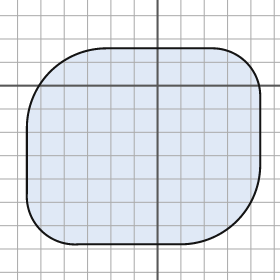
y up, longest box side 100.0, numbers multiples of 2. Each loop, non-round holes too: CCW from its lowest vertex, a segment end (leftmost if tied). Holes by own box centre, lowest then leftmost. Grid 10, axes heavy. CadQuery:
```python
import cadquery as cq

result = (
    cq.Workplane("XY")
    .moveTo(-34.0, -68.0)
    .lineTo(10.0, -68.0)
    .threePointArc((34.0, -58.0), (44.0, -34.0))
    .lineTo(44.0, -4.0)
    .threePointArc((38.0, 10.0), (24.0, 16.0))
    .lineTo(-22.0, 16.0)
    .threePointArc((-46.0, 6.0), (-56.0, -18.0))
    .lineTo(-56.0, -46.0)
    .threePointArc((-50.0, -62.0), (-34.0, -68.0))
    .close()
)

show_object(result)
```